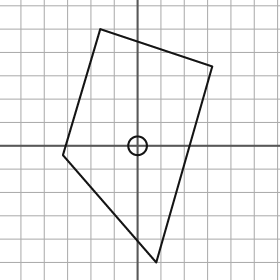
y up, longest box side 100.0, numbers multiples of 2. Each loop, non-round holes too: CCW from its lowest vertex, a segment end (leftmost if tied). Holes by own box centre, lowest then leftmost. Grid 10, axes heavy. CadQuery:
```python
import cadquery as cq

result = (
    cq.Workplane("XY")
    .moveTo(8.0, -50.0)
    .lineTo(32.0, 34.0)
    .lineTo(-16.0, 50.0)
    .lineTo(-32.0, -4.0)
    .close()
    .moveTo(0.0, 0.0)
    .circle(4.0)
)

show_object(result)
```